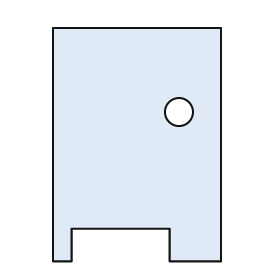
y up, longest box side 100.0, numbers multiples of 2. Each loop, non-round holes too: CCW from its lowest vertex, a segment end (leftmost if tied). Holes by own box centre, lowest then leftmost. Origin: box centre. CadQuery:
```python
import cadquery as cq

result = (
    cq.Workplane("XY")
    .moveTo(-36.0, -50.0)
    .lineTo(-28.0, -50.0)
    .lineTo(-28.0, -36.0)
    .lineTo(14.0, -36.0)
    .lineTo(14.0, -50.0)
    .lineTo(36.0, -50.0)
    .lineTo(36.0, 50.0)
    .lineTo(-36.0, 50.0)
    .close()
    .moveTo(18.0, 14.0)
    .circle(6.0)
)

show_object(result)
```